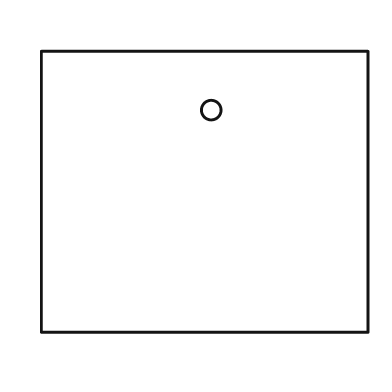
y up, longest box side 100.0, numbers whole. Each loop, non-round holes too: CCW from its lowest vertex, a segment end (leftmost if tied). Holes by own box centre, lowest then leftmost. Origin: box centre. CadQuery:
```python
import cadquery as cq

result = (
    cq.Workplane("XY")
    .moveTo(-50.0, -43.0)
    .lineTo(50.0, -43.0)
    .lineTo(50.0, 43.0)
    .lineTo(-50.0, 43.0)
    .close()
    .moveTo(2.0, 25.0)
    .circle(3.0)
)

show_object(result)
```